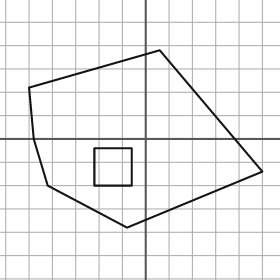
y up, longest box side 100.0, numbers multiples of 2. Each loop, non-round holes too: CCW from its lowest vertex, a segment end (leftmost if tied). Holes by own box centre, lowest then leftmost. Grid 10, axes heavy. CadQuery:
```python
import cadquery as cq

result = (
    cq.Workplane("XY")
    .moveTo(-8.0, -38.0)
    .lineTo(50.0, -14.0)
    .lineTo(6.0, 38.0)
    .lineTo(-50.0, 22.0)
    .lineTo(-48.0, 0.0)
    .lineTo(-42.0, -20.0)
    .close()
    .moveTo(-22.0, -20.0)
    .lineTo(-6.0, -20.0)
    .lineTo(-6.0, -4.0)
    .lineTo(-22.0, -4.0)
    .close()
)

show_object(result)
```